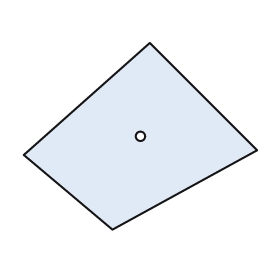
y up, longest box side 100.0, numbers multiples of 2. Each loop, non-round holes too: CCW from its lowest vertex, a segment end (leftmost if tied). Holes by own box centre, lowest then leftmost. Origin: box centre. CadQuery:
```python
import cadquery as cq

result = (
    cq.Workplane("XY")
    .moveTo(-12.0, -40.0)
    .lineTo(50.0, -6.0)
    .lineTo(4.0, 40.0)
    .lineTo(-50.0, -8.0)
    .close()
    .moveTo(0.0, 0.0)
    .circle(2.0)
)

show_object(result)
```